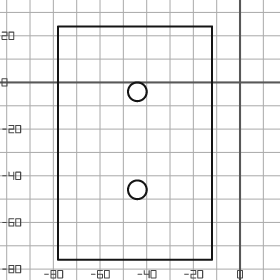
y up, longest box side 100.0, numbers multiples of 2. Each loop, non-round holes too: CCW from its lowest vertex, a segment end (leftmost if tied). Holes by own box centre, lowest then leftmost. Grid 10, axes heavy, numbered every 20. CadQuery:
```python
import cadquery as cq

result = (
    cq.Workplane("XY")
    .moveTo(-78.0, -76.0)
    .lineTo(-12.0, -76.0)
    .lineTo(-12.0, 24.0)
    .lineTo(-78.0, 24.0)
    .close()
    .moveTo(-44.0, -46.0)
    .circle(4.0)
    .moveTo(-44.0, -4.0)
    .circle(4.0)
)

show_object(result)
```